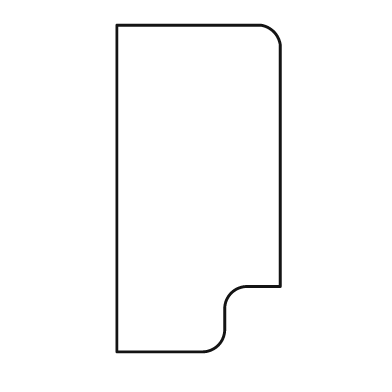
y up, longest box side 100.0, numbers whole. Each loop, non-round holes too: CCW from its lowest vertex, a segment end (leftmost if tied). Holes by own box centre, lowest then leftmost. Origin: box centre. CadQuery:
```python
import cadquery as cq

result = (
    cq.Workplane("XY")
    .moveTo(-25.0, -50.0)
    .lineTo(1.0, -50.0)
    .threePointArc((6.0, -48.0), (8.0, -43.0))
    .lineTo(8.0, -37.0)
    .threePointArc((10.0, -32.0), (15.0, -30.0))
    .lineTo(25.0, -30.0)
    .lineTo(25.0, 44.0)
    .threePointArc((23.0, 48.0), (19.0, 50.0))
    .lineTo(-25.0, 50.0)
    .close()
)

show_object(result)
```